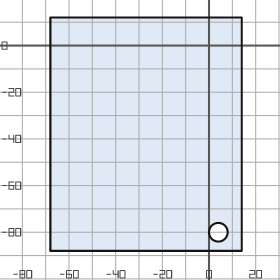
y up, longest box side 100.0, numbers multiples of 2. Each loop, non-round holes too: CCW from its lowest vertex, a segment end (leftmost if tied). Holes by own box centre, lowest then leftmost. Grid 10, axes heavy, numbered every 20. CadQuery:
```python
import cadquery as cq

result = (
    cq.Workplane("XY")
    .moveTo(-68.0, -88.0)
    .lineTo(14.0, -88.0)
    .lineTo(14.0, 12.0)
    .lineTo(-68.0, 12.0)
    .close()
    .moveTo(4.0, -80.0)
    .circle(4.0)
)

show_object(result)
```